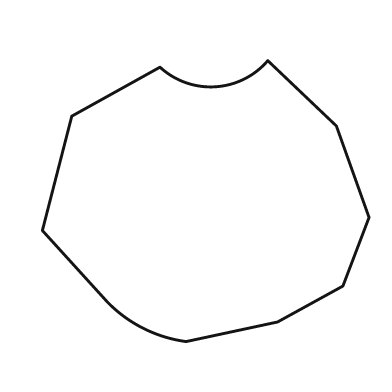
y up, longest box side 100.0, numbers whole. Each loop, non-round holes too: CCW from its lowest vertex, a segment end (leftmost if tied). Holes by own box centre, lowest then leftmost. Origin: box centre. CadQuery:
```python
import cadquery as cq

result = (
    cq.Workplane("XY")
    .moveTo(-6.0, -43.0)
    .lineTo(22.0, -37.0)
    .lineTo(42.0, -26.0)
    .lineTo(50.0, -5.0)
    .lineTo(40.0, 23.0)
    .lineTo(19.0, 43.0)
    .threePointArc((3.0, 35.0), (-14.0, 41.0))
    .lineTo(-41.0, 26.0)
    .lineTo(-50.0, -9.0)
    .lineTo(-30.0, -31.0)
    .threePointArc((-19.0, -39.0), (-6.0, -43.0))
    .close()
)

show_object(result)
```